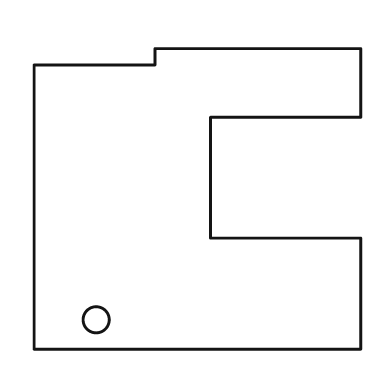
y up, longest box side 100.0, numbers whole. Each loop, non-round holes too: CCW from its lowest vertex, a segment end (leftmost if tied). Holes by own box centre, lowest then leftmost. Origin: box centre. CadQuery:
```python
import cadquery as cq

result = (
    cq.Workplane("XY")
    .moveTo(-50.0, -46.0)
    .lineTo(50.0, -46.0)
    .lineTo(50.0, -12.0)
    .lineTo(4.0, -12.0)
    .lineTo(4.0, 25.0)
    .lineTo(50.0, 25.0)
    .lineTo(50.0, 46.0)
    .lineTo(-13.0, 46.0)
    .lineTo(-13.0, 41.0)
    .lineTo(-50.0, 41.0)
    .close()
    .moveTo(-31.0, -37.0)
    .circle(4.0)
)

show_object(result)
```